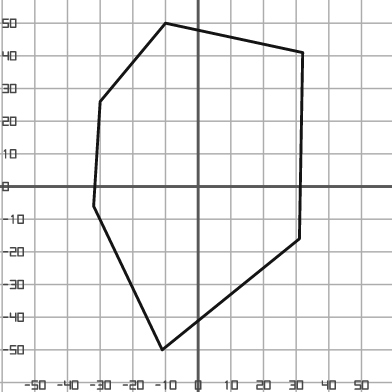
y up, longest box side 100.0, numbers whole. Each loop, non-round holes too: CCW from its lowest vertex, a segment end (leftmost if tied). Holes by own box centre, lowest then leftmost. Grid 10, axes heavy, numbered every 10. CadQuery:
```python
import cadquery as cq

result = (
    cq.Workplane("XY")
    .moveTo(-11.0, -50.0)
    .lineTo(31.0, -16.0)
    .lineTo(32.0, 41.0)
    .lineTo(-10.0, 50.0)
    .lineTo(-30.0, 26.0)
    .lineTo(-32.0, -6.0)
    .close()
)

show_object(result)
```